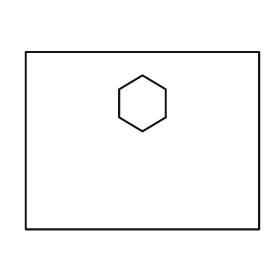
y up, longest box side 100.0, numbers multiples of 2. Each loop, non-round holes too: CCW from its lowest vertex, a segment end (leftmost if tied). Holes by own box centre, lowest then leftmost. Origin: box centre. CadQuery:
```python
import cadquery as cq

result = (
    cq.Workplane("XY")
    .moveTo(-50.0, -38.0)
    .lineTo(50.0, -38.0)
    .lineTo(50.0, 38.0)
    .lineTo(-50.0, 38.0)
    .close()
    .moveTo(0.0, 4.0)
    .lineTo(10.0, 10.0)
    .lineTo(10.0, 22.0)
    .lineTo(0.0, 28.0)
    .lineTo(-10.0, 22.0)
    .lineTo(-10.0, 10.0)
    .close()
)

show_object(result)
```